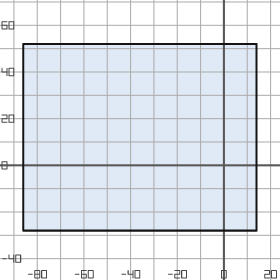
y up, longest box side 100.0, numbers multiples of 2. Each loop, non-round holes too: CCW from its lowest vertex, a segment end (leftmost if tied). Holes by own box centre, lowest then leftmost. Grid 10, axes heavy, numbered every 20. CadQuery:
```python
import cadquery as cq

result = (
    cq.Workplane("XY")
    .moveTo(-86.0, -28.0)
    .lineTo(14.0, -28.0)
    .lineTo(14.0, 52.0)
    .lineTo(-86.0, 52.0)
    .close()
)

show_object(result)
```